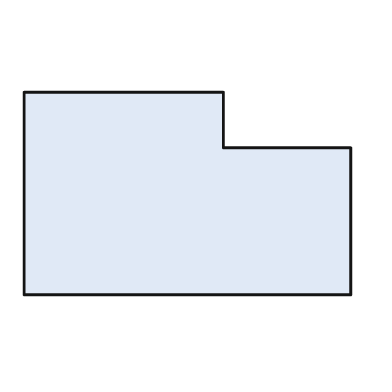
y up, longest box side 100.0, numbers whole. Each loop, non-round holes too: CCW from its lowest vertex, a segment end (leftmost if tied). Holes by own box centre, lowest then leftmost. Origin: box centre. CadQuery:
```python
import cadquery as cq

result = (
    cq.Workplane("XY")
    .moveTo(-50.0, -31.0)
    .lineTo(50.0, -31.0)
    .lineTo(50.0, 14.0)
    .lineTo(11.0, 14.0)
    .lineTo(11.0, 31.0)
    .lineTo(-50.0, 31.0)
    .close()
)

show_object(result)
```